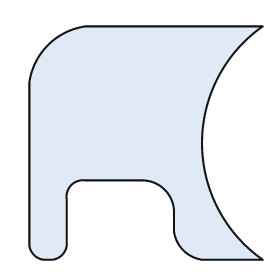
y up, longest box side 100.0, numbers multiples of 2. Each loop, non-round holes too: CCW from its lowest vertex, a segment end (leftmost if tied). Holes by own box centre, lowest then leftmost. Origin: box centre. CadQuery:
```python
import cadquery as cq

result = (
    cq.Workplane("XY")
    .moveTo(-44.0, -50.0)
    .lineTo(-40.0, -50.0)
    .threePointArc((-36.0, -48.0), (-34.0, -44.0))
    .lineTo(-34.0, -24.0)
    .threePointArc((-32.0, -18.0), (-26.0, -16.0))
    .lineTo(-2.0, -16.0)
    .threePointArc((8.0, -20.0), (12.0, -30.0))
    .lineTo(12.0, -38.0)
    .threePointArc((16.0, -46.0), (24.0, -50.0))
    .lineTo(50.0, -50.0)
    .threePointArc((24.0, 0.0), (50.0, 50.0))
    .lineTo(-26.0, 50.0)
    .threePointArc((-42.0, 42.0), (-50.0, 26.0))
    .lineTo(-50.0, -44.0)
    .threePointArc((-48.0, -48.0), (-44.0, -50.0))
    .close()
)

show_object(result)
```